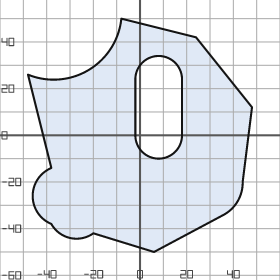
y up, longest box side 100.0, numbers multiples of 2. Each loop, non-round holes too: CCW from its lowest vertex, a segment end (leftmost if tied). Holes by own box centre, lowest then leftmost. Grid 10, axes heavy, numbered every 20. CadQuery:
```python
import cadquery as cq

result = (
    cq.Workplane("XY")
    .moveTo(6.0, -50.0)
    .lineTo(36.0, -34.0)
    .threePointArc((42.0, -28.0), (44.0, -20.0))
    .lineTo(48.0, 12.0)
    .lineTo(24.0, 42.0)
    .lineTo(-8.0, 50.0)
    .threePointArc((-22.0, 28.0), (-48.0, 26.0))
    .lineTo(-38.0, -14.0)
    .threePointArc((-46.0, -26.0), (-38.0, -38.0))
    .threePointArc((-30.0, -44.0), (-20.0, -42.0))
    .close()
    .moveTo(-2.0, 0.0)
    .threePointArc((8.0, -10.0), (18.0, 0.0))
    .lineTo(18.0, 24.0)
    .threePointArc((8.0, 34.0), (-2.0, 24.0))
    .close()
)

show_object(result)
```